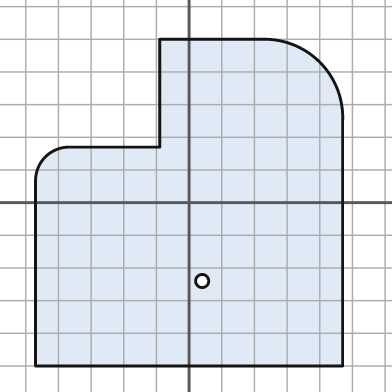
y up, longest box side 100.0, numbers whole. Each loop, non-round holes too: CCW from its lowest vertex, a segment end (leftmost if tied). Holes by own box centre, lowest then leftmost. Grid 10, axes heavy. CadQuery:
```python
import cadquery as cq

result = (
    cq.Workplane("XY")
    .moveTo(-47.0, -50.0)
    .lineTo(47.0, -50.0)
    .lineTo(47.0, 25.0)
    .threePointArc((40.0, 43.0), (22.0, 50.0))
    .lineTo(-9.0, 50.0)
    .lineTo(-9.0, 17.0)
    .lineTo(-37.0, 17.0)
    .threePointArc((-44.0, 14.0), (-47.0, 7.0))
    .close()
    .moveTo(4.0, -24.0)
    .circle(2.0)
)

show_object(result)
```